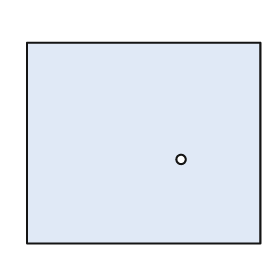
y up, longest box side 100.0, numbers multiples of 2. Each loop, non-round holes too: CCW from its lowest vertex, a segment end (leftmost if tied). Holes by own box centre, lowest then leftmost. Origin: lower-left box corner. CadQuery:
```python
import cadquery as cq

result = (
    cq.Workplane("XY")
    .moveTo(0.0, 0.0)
    .lineTo(100.0, 0.0)
    .lineTo(100.0, 86.0)
    .lineTo(0.0, 86.0)
    .close()
    .moveTo(66.0, 36.0)
    .circle(2.0)
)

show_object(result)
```